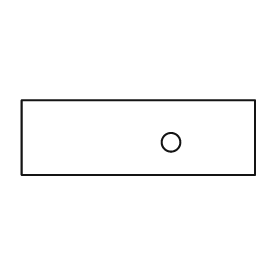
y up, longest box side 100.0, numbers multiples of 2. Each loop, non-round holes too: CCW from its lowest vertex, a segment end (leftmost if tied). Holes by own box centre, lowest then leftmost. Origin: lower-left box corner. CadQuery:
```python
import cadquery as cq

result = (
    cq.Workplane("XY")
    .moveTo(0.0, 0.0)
    .lineTo(100.0, 0.0)
    .lineTo(100.0, 32.0)
    .lineTo(0.0, 32.0)
    .close()
    .moveTo(64.0, 14.0)
    .circle(4.0)
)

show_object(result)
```